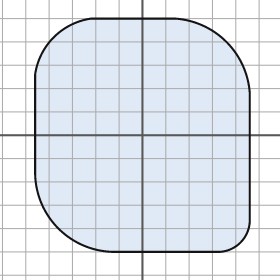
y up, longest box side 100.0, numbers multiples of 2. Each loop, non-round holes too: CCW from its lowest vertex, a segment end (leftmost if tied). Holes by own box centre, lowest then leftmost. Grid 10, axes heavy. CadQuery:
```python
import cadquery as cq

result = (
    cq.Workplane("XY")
    .moveTo(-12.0, -50.0)
    .lineTo(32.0, -50.0)
    .threePointArc((42.0, -46.0), (46.0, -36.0))
    .lineTo(46.0, 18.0)
    .threePointArc((36.0, 40.0), (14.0, 50.0))
    .lineTo(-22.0, 50.0)
    .threePointArc((-38.0, 42.0), (-46.0, 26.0))
    .lineTo(-46.0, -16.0)
    .threePointArc((-36.0, -40.0), (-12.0, -50.0))
    .close()
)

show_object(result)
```